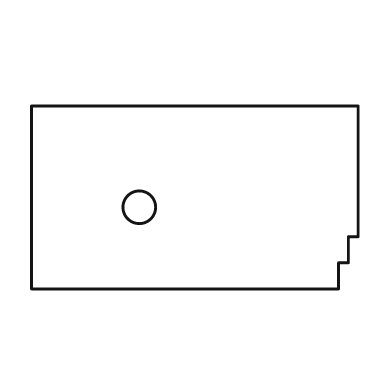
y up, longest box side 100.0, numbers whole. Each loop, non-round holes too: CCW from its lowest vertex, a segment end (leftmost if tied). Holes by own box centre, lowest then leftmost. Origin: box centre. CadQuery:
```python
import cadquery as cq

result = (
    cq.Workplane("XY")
    .moveTo(-50.0, -28.0)
    .lineTo(44.0, -28.0)
    .lineTo(44.0, -20.0)
    .lineTo(47.0, -20.0)
    .lineTo(47.0, -12.0)
    .lineTo(50.0, -12.0)
    .lineTo(50.0, 28.0)
    .lineTo(-50.0, 28.0)
    .close()
    .moveTo(-17.0, -3.0)
    .circle(5.0)
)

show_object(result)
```